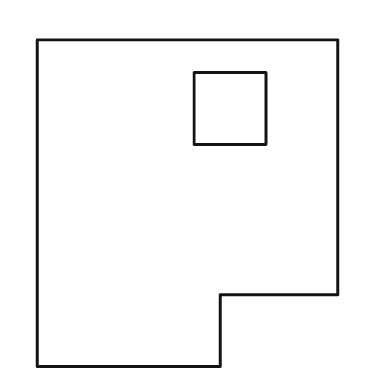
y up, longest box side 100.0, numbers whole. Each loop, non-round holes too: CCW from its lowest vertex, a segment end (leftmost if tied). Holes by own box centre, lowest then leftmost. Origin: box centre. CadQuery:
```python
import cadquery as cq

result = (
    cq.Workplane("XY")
    .moveTo(-46.0, -50.0)
    .lineTo(10.0, -50.0)
    .lineTo(10.0, -28.0)
    .lineTo(46.0, -28.0)
    .lineTo(46.0, 50.0)
    .lineTo(-46.0, 50.0)
    .close()
    .moveTo(2.0, 18.0)
    .lineTo(24.0, 18.0)
    .lineTo(24.0, 40.0)
    .lineTo(2.0, 40.0)
    .close()
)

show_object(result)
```